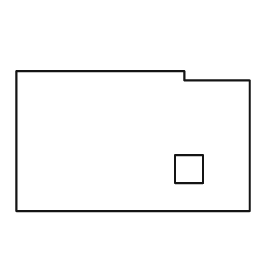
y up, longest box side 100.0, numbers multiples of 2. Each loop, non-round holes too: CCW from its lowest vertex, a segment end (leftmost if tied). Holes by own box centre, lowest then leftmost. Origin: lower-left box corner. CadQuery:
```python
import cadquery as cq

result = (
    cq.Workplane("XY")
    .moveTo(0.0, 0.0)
    .lineTo(100.0, 0.0)
    .lineTo(100.0, 56.0)
    .lineTo(72.0, 56.0)
    .lineTo(72.0, 60.0)
    .lineTo(0.0, 60.0)
    .close()
    .moveTo(68.0, 12.0)
    .lineTo(80.0, 12.0)
    .lineTo(80.0, 24.0)
    .lineTo(68.0, 24.0)
    .close()
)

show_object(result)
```